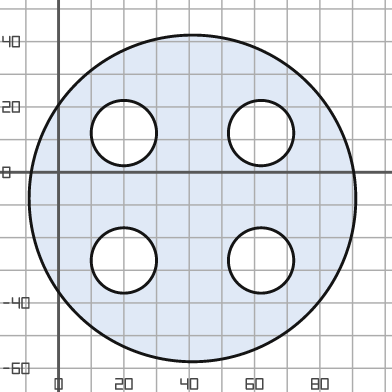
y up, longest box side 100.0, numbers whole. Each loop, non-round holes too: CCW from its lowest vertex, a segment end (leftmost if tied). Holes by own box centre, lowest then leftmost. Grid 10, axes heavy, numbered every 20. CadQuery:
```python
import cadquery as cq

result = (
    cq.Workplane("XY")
    .moveTo(41.0, -8.0)
    .circle(50.0)
    .moveTo(20.0, -27.0)
    .circle(10.0)
    .moveTo(62.0, -27.0)
    .circle(10.0)
    .moveTo(20.0, 12.0)
    .circle(10.0)
    .moveTo(62.0, 12.0)
    .circle(10.0)
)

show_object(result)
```